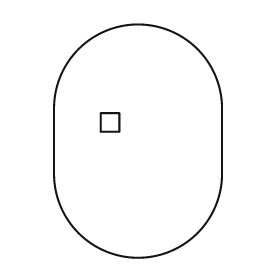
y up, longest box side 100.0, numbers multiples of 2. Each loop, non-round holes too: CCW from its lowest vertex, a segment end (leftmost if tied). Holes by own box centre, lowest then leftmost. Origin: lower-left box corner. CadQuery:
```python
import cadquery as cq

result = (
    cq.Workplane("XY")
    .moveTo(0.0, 36.0)
    .threePointArc((36.0, 0.0), (72.0, 36.0))
    .lineTo(72.0, 64.0)
    .threePointArc((36.0, 100.0), (0.0, 64.0))
    .close()
    .moveTo(20.0, 54.0)
    .lineTo(28.0, 54.0)
    .lineTo(28.0, 62.0)
    .lineTo(20.0, 62.0)
    .close()
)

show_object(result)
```